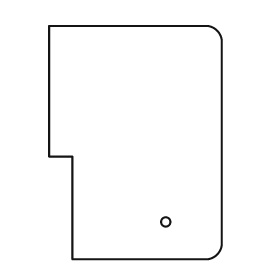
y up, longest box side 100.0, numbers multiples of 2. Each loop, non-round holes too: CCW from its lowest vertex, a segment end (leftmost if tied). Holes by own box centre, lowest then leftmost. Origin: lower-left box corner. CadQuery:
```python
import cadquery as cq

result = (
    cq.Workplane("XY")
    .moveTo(10.0, 0.0)
    .lineTo(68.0, 0.0)
    .threePointArc((72.0, 2.0), (74.0, 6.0))
    .lineTo(74.0, 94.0)
    .threePointArc((72.0, 98.0), (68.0, 100.0))
    .lineTo(0.0, 100.0)
    .lineTo(0.0, 44.0)
    .lineTo(10.0, 44.0)
    .close()
    .moveTo(50.0, 16.0)
    .circle(2.0)
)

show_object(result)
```